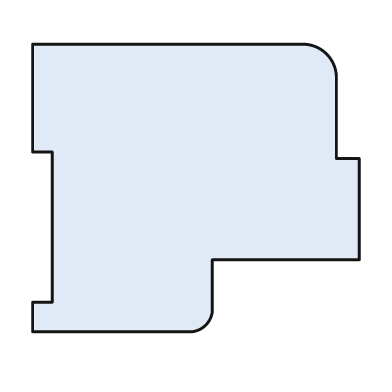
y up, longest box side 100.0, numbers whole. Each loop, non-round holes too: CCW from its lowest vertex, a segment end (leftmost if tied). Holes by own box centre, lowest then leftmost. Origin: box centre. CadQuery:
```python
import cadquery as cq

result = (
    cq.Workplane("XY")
    .moveTo(-50.0, -44.0)
    .lineTo(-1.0, -44.0)
    .threePointArc((3.0, -42.0), (5.0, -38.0))
    .lineTo(5.0, -22.0)
    .lineTo(50.0, -22.0)
    .lineTo(50.0, 9.0)
    .lineTo(43.0, 9.0)
    .lineTo(43.0, 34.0)
    .threePointArc((40.0, 41.0), (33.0, 44.0))
    .lineTo(-50.0, 44.0)
    .lineTo(-50.0, 11.0)
    .lineTo(-44.0, 11.0)
    .lineTo(-44.0, -35.0)
    .lineTo(-50.0, -35.0)
    .close()
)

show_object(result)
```